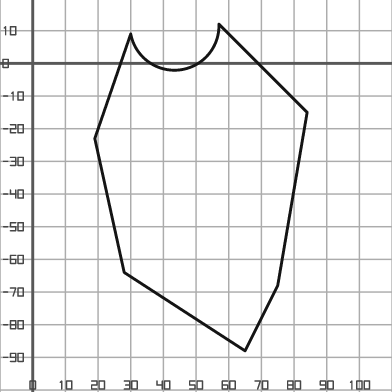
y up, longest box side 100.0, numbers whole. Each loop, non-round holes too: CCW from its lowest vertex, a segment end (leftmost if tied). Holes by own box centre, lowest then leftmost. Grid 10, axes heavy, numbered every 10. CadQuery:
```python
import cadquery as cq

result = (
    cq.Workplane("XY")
    .moveTo(65.0, -88.0)
    .lineTo(75.0, -68.0)
    .lineTo(84.0, -15.0)
    .lineTo(57.0, 12.0)
    .threePointArc((45.0, -2.0), (30.0, 9.0))
    .lineTo(19.0, -23.0)
    .lineTo(28.0, -64.0)
    .close()
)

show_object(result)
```